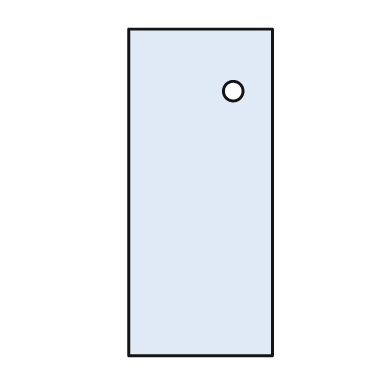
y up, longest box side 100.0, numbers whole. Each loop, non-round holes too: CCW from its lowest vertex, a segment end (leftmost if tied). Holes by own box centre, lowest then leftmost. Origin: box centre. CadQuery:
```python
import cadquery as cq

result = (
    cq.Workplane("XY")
    .moveTo(-22.0, -50.0)
    .lineTo(22.0, -50.0)
    .lineTo(22.0, 50.0)
    .lineTo(-22.0, 50.0)
    .close()
    .moveTo(10.0, 31.0)
    .circle(3.0)
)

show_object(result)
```